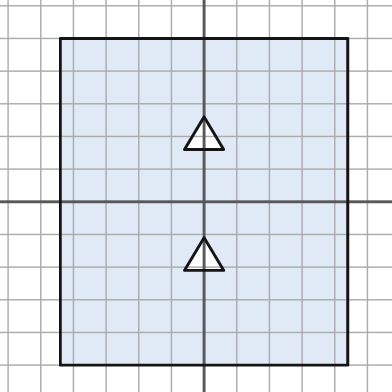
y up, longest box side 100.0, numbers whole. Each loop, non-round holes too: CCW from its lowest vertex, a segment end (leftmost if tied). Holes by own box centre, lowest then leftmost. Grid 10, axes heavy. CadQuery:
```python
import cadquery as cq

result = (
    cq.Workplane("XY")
    .moveTo(-44.0, -50.0)
    .lineTo(44.0, -50.0)
    .lineTo(44.0, 50.0)
    .lineTo(-44.0, 50.0)
    .close()
    .moveTo(-6.0, -21.0)
    .lineTo(6.0, -21.0)
    .lineTo(0.0, -11.0)
    .close()
    .moveTo(-6.0, 16.0)
    .lineTo(6.0, 16.0)
    .lineTo(0.0, 26.0)
    .close()
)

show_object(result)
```